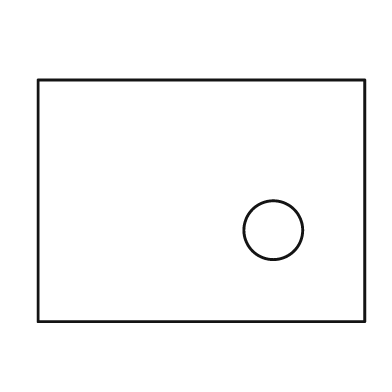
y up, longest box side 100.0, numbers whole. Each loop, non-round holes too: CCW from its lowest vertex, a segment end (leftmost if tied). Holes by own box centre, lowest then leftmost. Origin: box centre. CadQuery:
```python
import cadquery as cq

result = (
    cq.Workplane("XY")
    .moveTo(-50.0, -37.0)
    .lineTo(50.0, -37.0)
    .lineTo(50.0, 37.0)
    .lineTo(-50.0, 37.0)
    .close()
    .moveTo(22.0, -9.0)
    .circle(9.0)
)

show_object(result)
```